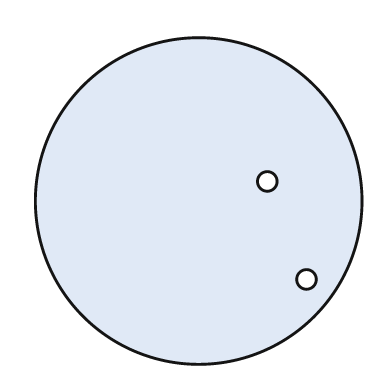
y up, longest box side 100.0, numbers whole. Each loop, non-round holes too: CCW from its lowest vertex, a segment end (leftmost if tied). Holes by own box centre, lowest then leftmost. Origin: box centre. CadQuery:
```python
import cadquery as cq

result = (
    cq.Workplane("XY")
    .moveTo(0.0, 0.0)
    .circle(50.0)
    .moveTo(33.0, -24.0)
    .circle(3.0)
    .moveTo(21.0, 6.0)
    .circle(3.0)
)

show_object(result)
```